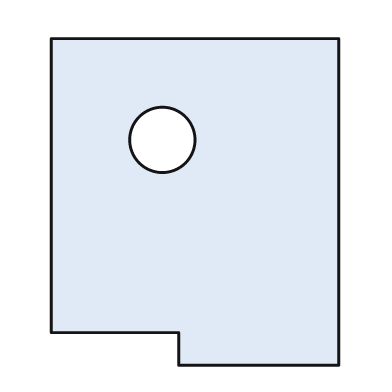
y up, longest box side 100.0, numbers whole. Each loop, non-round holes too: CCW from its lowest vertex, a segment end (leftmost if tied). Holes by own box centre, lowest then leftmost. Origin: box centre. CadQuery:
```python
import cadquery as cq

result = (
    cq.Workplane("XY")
    .moveTo(-5.0, -50.0)
    .lineTo(44.0, -50.0)
    .lineTo(44.0, 50.0)
    .lineTo(-44.0, 50.0)
    .lineTo(-44.0, -40.0)
    .lineTo(-5.0, -40.0)
    .close()
    .moveTo(-10.0, 19.0)
    .circle(10.0)
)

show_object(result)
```